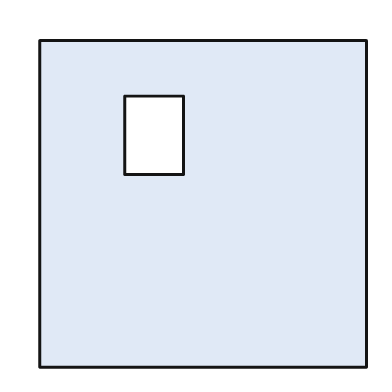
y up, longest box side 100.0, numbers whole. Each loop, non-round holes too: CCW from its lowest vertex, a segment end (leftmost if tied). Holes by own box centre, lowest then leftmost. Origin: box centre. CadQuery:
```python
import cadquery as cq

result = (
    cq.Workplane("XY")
    .moveTo(-50.0, -50.0)
    .lineTo(50.0, -50.0)
    .lineTo(50.0, 50.0)
    .lineTo(-50.0, 50.0)
    .close()
    .moveTo(-24.0, 9.0)
    .lineTo(-6.0, 9.0)
    .lineTo(-6.0, 33.0)
    .lineTo(-24.0, 33.0)
    .close()
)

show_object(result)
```